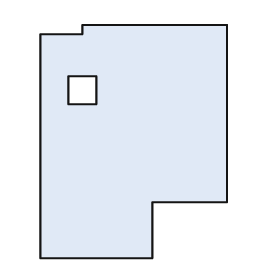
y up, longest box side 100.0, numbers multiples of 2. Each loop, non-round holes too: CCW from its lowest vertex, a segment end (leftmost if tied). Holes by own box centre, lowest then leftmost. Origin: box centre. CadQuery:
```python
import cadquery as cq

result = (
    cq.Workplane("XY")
    .moveTo(-40.0, -50.0)
    .lineTo(8.0, -50.0)
    .lineTo(8.0, -26.0)
    .lineTo(40.0, -26.0)
    .lineTo(40.0, 50.0)
    .lineTo(-22.0, 50.0)
    .lineTo(-22.0, 46.0)
    .lineTo(-40.0, 46.0)
    .close()
    .moveTo(-28.0, 16.0)
    .lineTo(-16.0, 16.0)
    .lineTo(-16.0, 28.0)
    .lineTo(-28.0, 28.0)
    .close()
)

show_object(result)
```